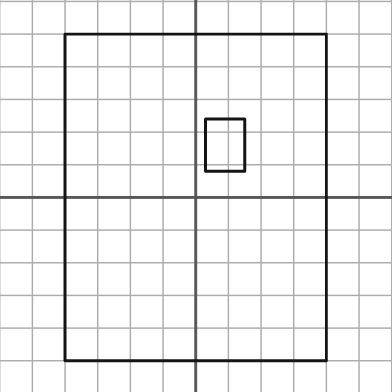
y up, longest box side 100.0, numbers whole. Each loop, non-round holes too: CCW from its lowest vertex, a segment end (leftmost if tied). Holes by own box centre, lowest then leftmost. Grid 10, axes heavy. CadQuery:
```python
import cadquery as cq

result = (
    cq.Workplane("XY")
    .moveTo(-40.0, -50.0)
    .lineTo(40.0, -50.0)
    .lineTo(40.0, 50.0)
    .lineTo(-40.0, 50.0)
    .close()
    .moveTo(3.0, 8.0)
    .lineTo(15.0, 8.0)
    .lineTo(15.0, 24.0)
    .lineTo(3.0, 24.0)
    .close()
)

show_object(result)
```